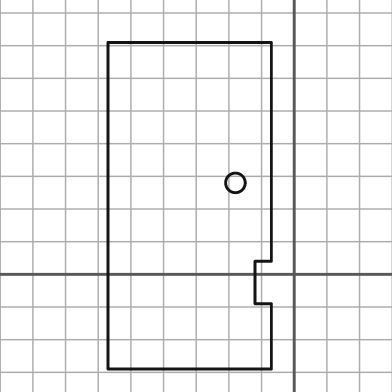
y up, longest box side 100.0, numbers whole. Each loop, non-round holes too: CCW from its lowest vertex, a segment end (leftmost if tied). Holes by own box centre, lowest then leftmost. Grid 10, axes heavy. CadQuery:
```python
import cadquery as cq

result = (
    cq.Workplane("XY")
    .moveTo(-57.0, -29.0)
    .lineTo(-7.0, -29.0)
    .lineTo(-7.0, -9.0)
    .lineTo(-12.0, -9.0)
    .lineTo(-12.0, 4.0)
    .lineTo(-7.0, 4.0)
    .lineTo(-7.0, 71.0)
    .lineTo(-57.0, 71.0)
    .close()
    .moveTo(-18.0, 28.0)
    .circle(3.0)
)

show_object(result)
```